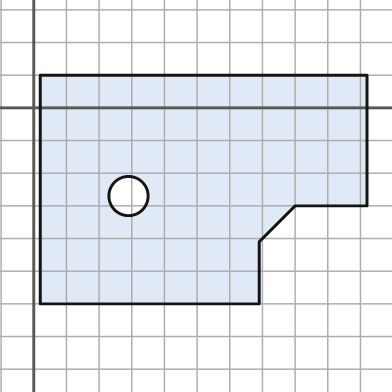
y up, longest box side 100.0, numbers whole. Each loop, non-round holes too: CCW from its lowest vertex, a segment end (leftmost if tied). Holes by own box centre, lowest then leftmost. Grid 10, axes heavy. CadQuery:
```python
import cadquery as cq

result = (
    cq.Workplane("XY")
    .moveTo(2.0, -60.0)
    .lineTo(69.0, -60.0)
    .lineTo(69.0, -41.0)
    .lineTo(80.0, -30.0)
    .lineTo(102.0, -30.0)
    .lineTo(102.0, 10.0)
    .lineTo(2.0, 10.0)
    .close()
    .moveTo(29.0, -27.0)
    .circle(6.0)
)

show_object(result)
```